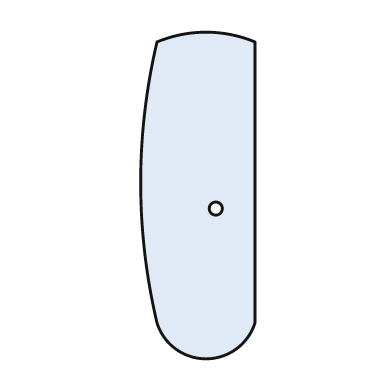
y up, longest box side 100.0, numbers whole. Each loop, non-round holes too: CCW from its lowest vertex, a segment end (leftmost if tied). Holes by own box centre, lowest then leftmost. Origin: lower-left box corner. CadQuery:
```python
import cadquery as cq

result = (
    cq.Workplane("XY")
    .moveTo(5.0, 11.0)
    .threePointArc((20.0, 0.0), (35.0, 11.0))
    .lineTo(35.0, 97.0)
    .threePointArc((20.0, 100.0), (5.0, 97.0))
    .threePointArc((0.0, 54.0), (5.0, 11.0))
    .close()
    .moveTo(23.0, 46.0)
    .circle(2.0)
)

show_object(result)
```